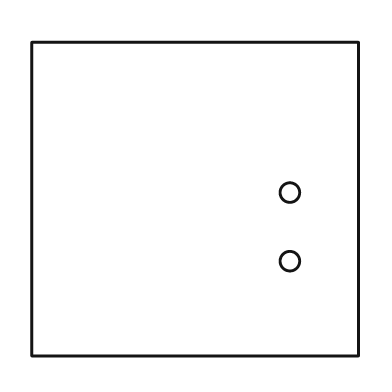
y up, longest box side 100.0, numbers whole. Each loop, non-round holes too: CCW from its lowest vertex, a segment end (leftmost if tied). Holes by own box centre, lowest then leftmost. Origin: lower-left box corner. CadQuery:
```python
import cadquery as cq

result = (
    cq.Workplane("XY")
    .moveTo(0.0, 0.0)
    .lineTo(100.0, 0.0)
    .lineTo(100.0, 96.0)
    .lineTo(0.0, 96.0)
    .close()
    .moveTo(79.0, 29.0)
    .circle(3.0)
    .moveTo(79.0, 50.0)
    .circle(3.0)
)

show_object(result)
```